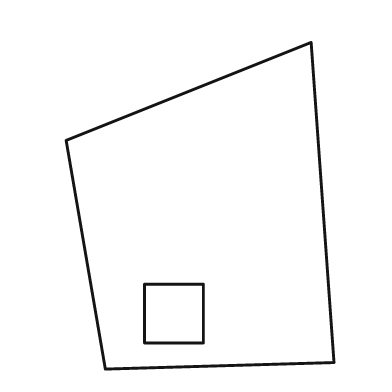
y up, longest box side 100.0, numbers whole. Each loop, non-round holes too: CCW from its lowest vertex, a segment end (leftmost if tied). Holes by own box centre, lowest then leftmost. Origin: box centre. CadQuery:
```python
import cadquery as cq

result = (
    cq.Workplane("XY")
    .moveTo(-29.0, -50.0)
    .lineTo(41.0, -48.0)
    .lineTo(34.0, 50.0)
    .lineTo(-41.0, 20.0)
    .close()
    .moveTo(-17.0, -42.0)
    .lineTo(1.0, -42.0)
    .lineTo(1.0, -24.0)
    .lineTo(-17.0, -24.0)
    .close()
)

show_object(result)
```